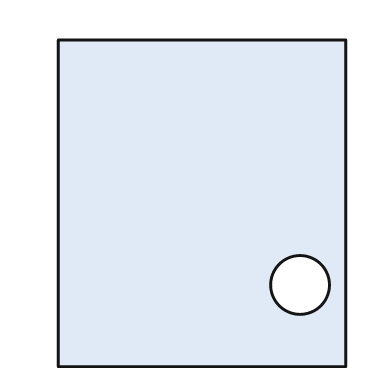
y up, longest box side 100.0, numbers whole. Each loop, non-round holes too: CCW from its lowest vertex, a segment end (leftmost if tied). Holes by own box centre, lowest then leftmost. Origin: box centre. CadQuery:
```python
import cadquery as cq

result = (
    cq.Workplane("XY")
    .moveTo(-44.0, -50.0)
    .lineTo(44.0, -50.0)
    .lineTo(44.0, 50.0)
    .lineTo(-44.0, 50.0)
    .close()
    .moveTo(30.0, -25.0)
    .circle(9.0)
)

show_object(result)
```